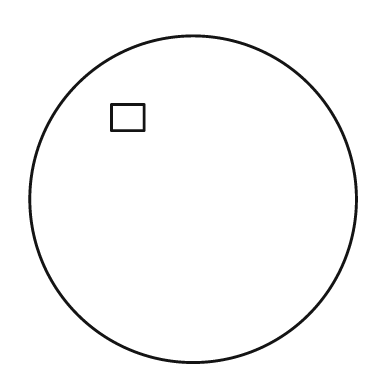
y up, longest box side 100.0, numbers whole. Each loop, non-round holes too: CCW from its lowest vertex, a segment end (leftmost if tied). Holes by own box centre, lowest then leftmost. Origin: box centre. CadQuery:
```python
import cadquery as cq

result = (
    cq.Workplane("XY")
    .moveTo(0.0, 0.0)
    .circle(50.0)
    .moveTo(-25.0, 21.0)
    .lineTo(-15.0, 21.0)
    .lineTo(-15.0, 29.0)
    .lineTo(-25.0, 29.0)
    .close()
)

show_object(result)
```